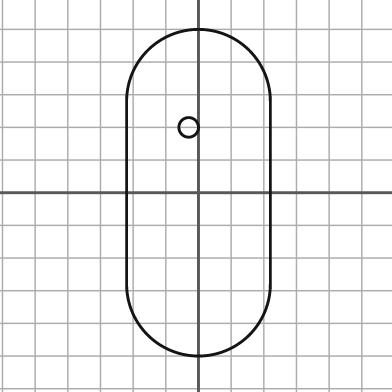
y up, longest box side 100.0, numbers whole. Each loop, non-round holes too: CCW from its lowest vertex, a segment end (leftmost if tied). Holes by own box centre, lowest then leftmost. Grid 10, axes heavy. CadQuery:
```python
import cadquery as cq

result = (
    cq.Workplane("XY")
    .moveTo(-22.0, -28.0)
    .threePointArc((0.0, -50.0), (22.0, -28.0))
    .lineTo(22.0, 28.0)
    .threePointArc((0.0, 50.0), (-22.0, 28.0))
    .close()
    .moveTo(-3.0, 20.0)
    .circle(3.0)
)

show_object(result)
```